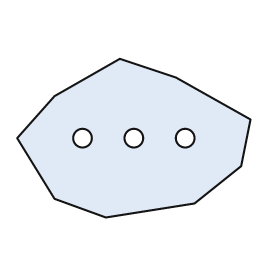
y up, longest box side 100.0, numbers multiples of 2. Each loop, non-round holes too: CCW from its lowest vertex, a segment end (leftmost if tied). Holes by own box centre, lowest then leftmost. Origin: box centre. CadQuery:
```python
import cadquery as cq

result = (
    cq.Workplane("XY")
    .moveTo(-12.0, -34.0)
    .lineTo(26.0, -28.0)
    .lineTo(46.0, -12.0)
    .lineTo(50.0, 8.0)
    .lineTo(18.0, 26.0)
    .lineTo(-6.0, 34.0)
    .lineTo(-34.0, 18.0)
    .lineTo(-50.0, 0.0)
    .lineTo(-34.0, -26.0)
    .close()
    .moveTo(-22.0, 0.0)
    .circle(4.0)
    .moveTo(0.0, 0.0)
    .circle(4.0)
    .moveTo(22.0, 0.0)
    .circle(4.0)
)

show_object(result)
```